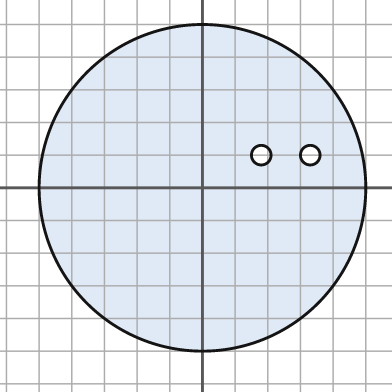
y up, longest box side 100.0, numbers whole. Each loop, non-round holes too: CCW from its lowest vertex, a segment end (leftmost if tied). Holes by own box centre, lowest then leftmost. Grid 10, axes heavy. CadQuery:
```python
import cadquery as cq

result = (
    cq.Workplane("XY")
    .moveTo(0.0, 0.0)
    .circle(50.0)
    .moveTo(18.0, 10.0)
    .circle(3.0)
    .moveTo(33.0, 10.0)
    .circle(3.0)
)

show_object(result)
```